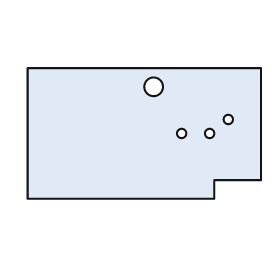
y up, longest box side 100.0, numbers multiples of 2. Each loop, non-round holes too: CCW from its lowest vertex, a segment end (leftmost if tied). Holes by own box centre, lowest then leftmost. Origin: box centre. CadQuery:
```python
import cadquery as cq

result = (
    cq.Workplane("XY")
    .moveTo(-50.0, -28.0)
    .lineTo(30.0, -28.0)
    .lineTo(30.0, -20.0)
    .lineTo(50.0, -20.0)
    .lineTo(50.0, 28.0)
    .lineTo(-50.0, 28.0)
    .close()
    .moveTo(16.0, 0.0)
    .circle(2.0)
    .moveTo(28.0, 0.0)
    .circle(2.0)
    .moveTo(36.0, 6.0)
    .circle(2.0)
    .moveTo(4.0, 20.0)
    .circle(4.0)
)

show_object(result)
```